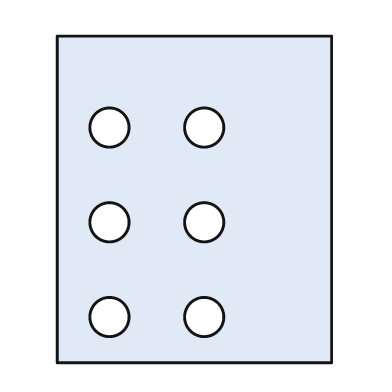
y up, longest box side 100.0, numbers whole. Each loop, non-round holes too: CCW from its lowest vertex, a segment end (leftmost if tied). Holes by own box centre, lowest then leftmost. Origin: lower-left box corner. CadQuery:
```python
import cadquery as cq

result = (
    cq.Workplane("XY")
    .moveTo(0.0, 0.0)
    .lineTo(84.0, 0.0)
    .lineTo(84.0, 100.0)
    .lineTo(0.0, 100.0)
    .close()
    .moveTo(16.0, 14.0)
    .circle(6.0)
    .moveTo(45.0, 14.0)
    .circle(6.0)
    .moveTo(16.0, 43.0)
    .circle(6.0)
    .moveTo(45.0, 43.0)
    .circle(6.0)
    .moveTo(16.0, 72.0)
    .circle(6.0)
    .moveTo(45.0, 72.0)
    .circle(6.0)
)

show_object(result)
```